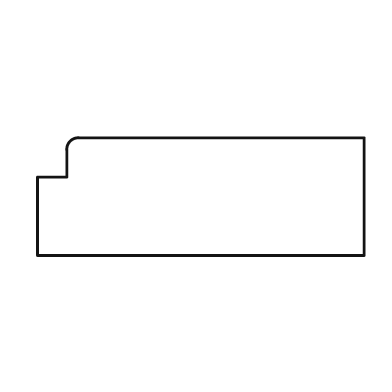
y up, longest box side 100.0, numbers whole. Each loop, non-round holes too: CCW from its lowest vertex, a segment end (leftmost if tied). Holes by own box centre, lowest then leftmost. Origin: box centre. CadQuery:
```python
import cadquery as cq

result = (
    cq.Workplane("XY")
    .moveTo(-50.0, -18.0)
    .lineTo(50.0, -18.0)
    .lineTo(50.0, 18.0)
    .lineTo(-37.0, 18.0)
    .threePointArc((-40.0, 17.0), (-41.0, 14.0))
    .lineTo(-41.0, 6.0)
    .lineTo(-50.0, 6.0)
    .close()
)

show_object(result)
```